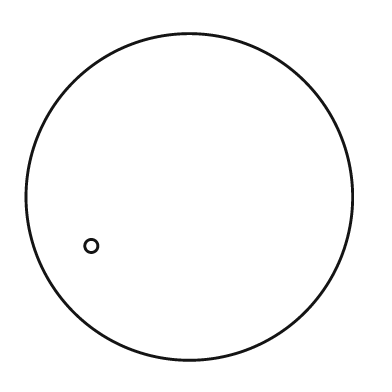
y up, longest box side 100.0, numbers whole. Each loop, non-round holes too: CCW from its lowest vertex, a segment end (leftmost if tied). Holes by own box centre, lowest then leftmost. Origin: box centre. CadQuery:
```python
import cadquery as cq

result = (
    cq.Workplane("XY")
    .moveTo(0.0, 0.0)
    .circle(50.0)
    .moveTo(-30.0, -15.0)
    .circle(2.0)
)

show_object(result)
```